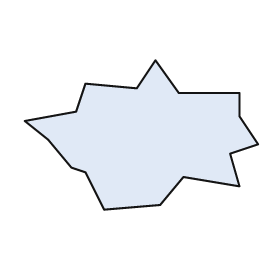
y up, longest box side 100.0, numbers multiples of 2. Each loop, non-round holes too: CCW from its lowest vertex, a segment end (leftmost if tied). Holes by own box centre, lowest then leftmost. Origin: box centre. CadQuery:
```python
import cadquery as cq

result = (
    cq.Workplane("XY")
    .moveTo(-16.0, -32.0)
    .lineTo(8.0, -30.0)
    .lineTo(18.0, -18.0)
    .lineTo(42.0, -22.0)
    .lineTo(38.0, -8.0)
    .lineTo(50.0, -4.0)
    .lineTo(42.0, 8.0)
    .lineTo(42.0, 18.0)
    .lineTo(16.0, 18.0)
    .lineTo(6.0, 32.0)
    .lineTo(-2.0, 20.0)
    .lineTo(-24.0, 22.0)
    .lineTo(-28.0, 10.0)
    .lineTo(-50.0, 6.0)
    .lineTo(-40.0, -2.0)
    .lineTo(-30.0, -14.0)
    .lineTo(-24.0, -16.0)
    .close()
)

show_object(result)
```